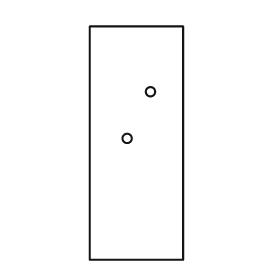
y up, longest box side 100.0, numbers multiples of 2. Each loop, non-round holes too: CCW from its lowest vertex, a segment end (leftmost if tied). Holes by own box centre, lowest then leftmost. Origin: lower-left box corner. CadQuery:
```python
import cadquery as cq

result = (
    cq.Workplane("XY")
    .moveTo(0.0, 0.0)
    .lineTo(40.0, 0.0)
    .lineTo(40.0, 100.0)
    .lineTo(0.0, 100.0)
    .close()
    .moveTo(16.0, 52.0)
    .circle(2.0)
    .moveTo(26.0, 72.0)
    .circle(2.0)
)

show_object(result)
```